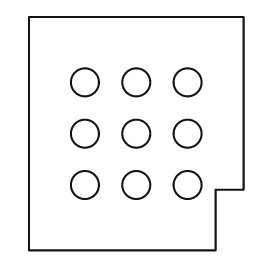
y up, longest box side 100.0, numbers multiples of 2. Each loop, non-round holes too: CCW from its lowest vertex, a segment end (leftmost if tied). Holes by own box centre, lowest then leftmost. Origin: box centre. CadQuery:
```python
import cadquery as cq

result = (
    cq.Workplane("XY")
    .moveTo(-46.0, -50.0)
    .lineTo(34.0, -50.0)
    .lineTo(34.0, -24.0)
    .lineTo(46.0, -24.0)
    .lineTo(46.0, 50.0)
    .lineTo(-46.0, 50.0)
    .close()
    .moveTo(-22.0, -22.0)
    .circle(6.0)
    .moveTo(0.0, -22.0)
    .circle(6.0)
    .moveTo(22.0, -22.0)
    .circle(6.0)
    .moveTo(-22.0, 0.0)
    .circle(6.0)
    .moveTo(0.0, 0.0)
    .circle(6.0)
    .moveTo(22.0, 0.0)
    .circle(6.0)
    .moveTo(-22.0, 22.0)
    .circle(6.0)
    .moveTo(0.0, 22.0)
    .circle(6.0)
    .moveTo(22.0, 22.0)
    .circle(6.0)
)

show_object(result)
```